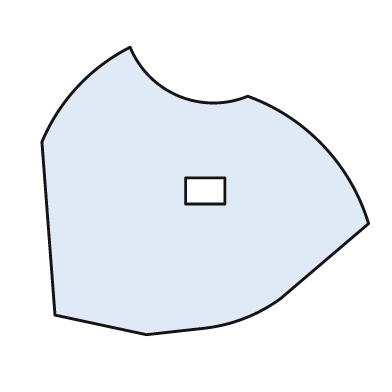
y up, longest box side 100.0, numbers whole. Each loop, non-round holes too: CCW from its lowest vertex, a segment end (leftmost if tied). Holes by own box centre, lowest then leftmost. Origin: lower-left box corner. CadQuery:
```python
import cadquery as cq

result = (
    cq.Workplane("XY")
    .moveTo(32.0, 0.0)
    .lineTo(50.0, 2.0)
    .threePointArc((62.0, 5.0), (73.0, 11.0))
    .lineTo(100.0, 34.0)
    .threePointArc((86.0, 58.0), (63.0, 73.0))
    .threePointArc((42.0, 73.0), (27.0, 88.0))
    .threePointArc((11.0, 76.0), (0.0, 59.0))
    .lineTo(4.0, 6.0)
    .close()
    .moveTo(44.0, 40.0)
    .lineTo(56.0, 40.0)
    .lineTo(56.0, 48.0)
    .lineTo(44.0, 48.0)
    .close()
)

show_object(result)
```